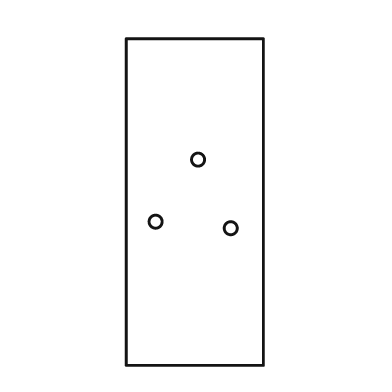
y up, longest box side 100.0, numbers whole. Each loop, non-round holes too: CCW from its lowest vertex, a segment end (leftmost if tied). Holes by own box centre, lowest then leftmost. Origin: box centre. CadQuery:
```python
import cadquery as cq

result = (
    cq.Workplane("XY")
    .moveTo(-21.0, -50.0)
    .lineTo(21.0, -50.0)
    .lineTo(21.0, 50.0)
    .lineTo(-21.0, 50.0)
    .close()
    .moveTo(11.0, -8.0)
    .circle(2.0)
    .moveTo(-12.0, -6.0)
    .circle(2.0)
    .moveTo(1.0, 13.0)
    .circle(2.0)
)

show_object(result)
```